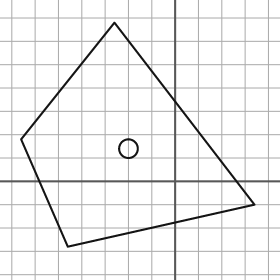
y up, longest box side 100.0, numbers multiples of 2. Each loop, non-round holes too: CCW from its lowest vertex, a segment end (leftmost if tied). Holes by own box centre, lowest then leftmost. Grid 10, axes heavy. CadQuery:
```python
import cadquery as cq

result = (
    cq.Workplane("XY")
    .moveTo(-46.0, -28.0)
    .lineTo(34.0, -10.0)
    .lineTo(-26.0, 68.0)
    .lineTo(-66.0, 18.0)
    .close()
    .moveTo(-20.0, 14.0)
    .circle(4.0)
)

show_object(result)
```